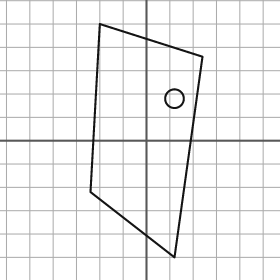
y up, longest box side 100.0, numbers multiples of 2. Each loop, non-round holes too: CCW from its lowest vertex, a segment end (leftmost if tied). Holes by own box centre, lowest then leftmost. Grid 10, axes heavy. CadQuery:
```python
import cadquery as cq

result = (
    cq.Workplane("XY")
    .moveTo(12.0, -50.0)
    .lineTo(24.0, 36.0)
    .lineTo(-20.0, 50.0)
    .lineTo(-24.0, -22.0)
    .close()
    .moveTo(12.0, 18.0)
    .circle(4.0)
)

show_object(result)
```